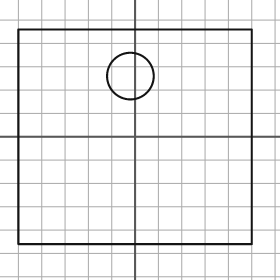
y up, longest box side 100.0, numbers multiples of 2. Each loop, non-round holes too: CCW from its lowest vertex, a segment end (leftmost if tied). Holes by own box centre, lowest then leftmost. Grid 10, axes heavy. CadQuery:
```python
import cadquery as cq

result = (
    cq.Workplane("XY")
    .moveTo(-50.0, -46.0)
    .lineTo(50.0, -46.0)
    .lineTo(50.0, 46.0)
    .lineTo(-50.0, 46.0)
    .close()
    .moveTo(-2.0, 26.0)
    .circle(10.0)
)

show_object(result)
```